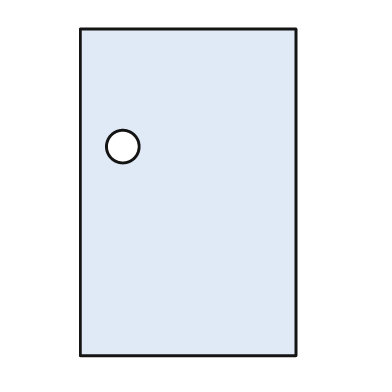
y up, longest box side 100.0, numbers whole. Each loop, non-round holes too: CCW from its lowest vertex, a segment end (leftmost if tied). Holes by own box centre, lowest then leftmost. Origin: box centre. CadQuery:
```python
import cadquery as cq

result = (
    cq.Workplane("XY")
    .moveTo(-33.0, -50.0)
    .lineTo(33.0, -50.0)
    .lineTo(33.0, 50.0)
    .lineTo(-33.0, 50.0)
    .close()
    .moveTo(-20.0, 14.0)
    .circle(5.0)
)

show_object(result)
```